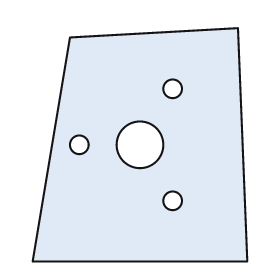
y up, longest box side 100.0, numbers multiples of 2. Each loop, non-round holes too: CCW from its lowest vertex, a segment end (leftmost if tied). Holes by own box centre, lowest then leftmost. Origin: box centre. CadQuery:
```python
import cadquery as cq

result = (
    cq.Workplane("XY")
    .moveTo(-46.0, -50.0)
    .lineTo(46.0, -50.0)
    .lineTo(42.0, 50.0)
    .lineTo(-30.0, 46.0)
    .close()
    .moveTo(14.0, -24.0)
    .circle(4.0)
    .moveTo(-26.0, 0.0)
    .circle(4.0)
    .moveTo(0.0, 0.0)
    .circle(10.0)
    .moveTo(14.0, 24.0)
    .circle(4.0)
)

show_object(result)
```